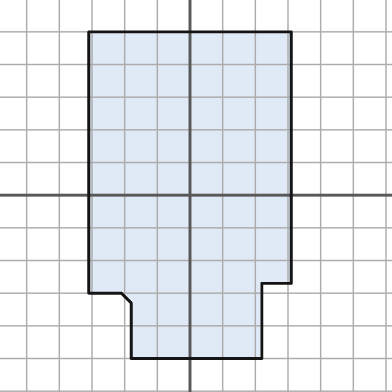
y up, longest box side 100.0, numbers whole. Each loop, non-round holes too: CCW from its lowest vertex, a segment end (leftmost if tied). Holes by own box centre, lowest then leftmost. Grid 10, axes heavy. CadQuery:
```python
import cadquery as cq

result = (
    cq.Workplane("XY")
    .moveTo(-18.0, -50.0)
    .lineTo(22.0, -50.0)
    .lineTo(22.0, -27.0)
    .lineTo(31.0, -27.0)
    .lineTo(31.0, 50.0)
    .lineTo(-31.0, 50.0)
    .lineTo(-31.0, -30.0)
    .lineTo(-21.0, -30.0)
    .lineTo(-18.0, -33.0)
    .close()
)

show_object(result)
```